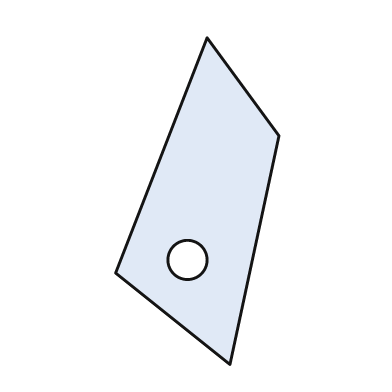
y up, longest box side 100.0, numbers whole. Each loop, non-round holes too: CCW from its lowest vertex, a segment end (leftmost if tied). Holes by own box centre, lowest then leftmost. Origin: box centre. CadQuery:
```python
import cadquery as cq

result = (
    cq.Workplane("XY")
    .moveTo(10.0, -50.0)
    .lineTo(25.0, 20.0)
    .lineTo(3.0, 50.0)
    .lineTo(-25.0, -22.0)
    .close()
    .moveTo(-3.0, -18.0)
    .circle(6.0)
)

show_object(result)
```